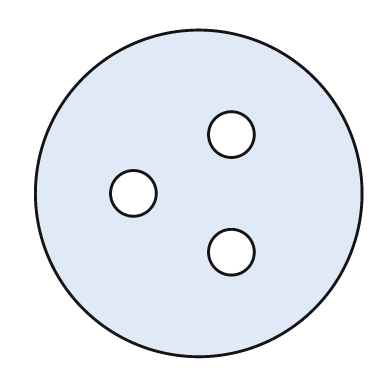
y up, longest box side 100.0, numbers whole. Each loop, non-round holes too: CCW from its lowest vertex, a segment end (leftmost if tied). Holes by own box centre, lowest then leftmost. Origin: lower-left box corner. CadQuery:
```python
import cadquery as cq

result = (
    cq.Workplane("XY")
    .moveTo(50.0, 50.0)
    .circle(50.0)
    .moveTo(60.0, 32.0)
    .circle(7.0)
    .moveTo(30.0, 50.0)
    .circle(7.0)
    .moveTo(60.0, 68.0)
    .circle(7.0)
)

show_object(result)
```